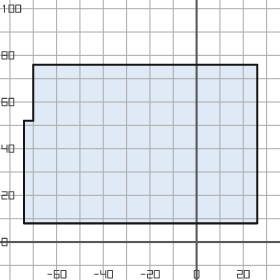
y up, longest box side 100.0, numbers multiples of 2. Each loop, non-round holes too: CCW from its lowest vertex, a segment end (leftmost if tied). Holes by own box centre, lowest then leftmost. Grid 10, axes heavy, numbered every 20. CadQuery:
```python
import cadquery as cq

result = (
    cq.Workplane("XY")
    .moveTo(-74.0, 8.0)
    .lineTo(26.0, 8.0)
    .lineTo(26.0, 76.0)
    .lineTo(-70.0, 76.0)
    .lineTo(-70.0, 52.0)
    .lineTo(-74.0, 52.0)
    .close()
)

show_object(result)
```